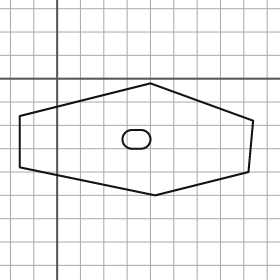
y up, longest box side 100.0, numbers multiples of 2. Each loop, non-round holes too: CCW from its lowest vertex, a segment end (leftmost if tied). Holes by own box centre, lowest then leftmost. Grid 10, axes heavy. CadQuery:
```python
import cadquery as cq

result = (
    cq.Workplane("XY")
    .moveTo(42.0, -50.0)
    .lineTo(82.0, -40.0)
    .lineTo(84.0, -18.0)
    .lineTo(40.0, -2.0)
    .lineTo(-16.0, -16.0)
    .lineTo(-16.0, -38.0)
    .close()
    .moveTo(32.0, -30.0)
    .lineTo(36.0, -30.0)
    .threePointArc((40.0, -26.0), (36.0, -22.0))
    .lineTo(32.0, -22.0)
    .threePointArc((28.0, -26.0), (32.0, -30.0))
    .close()
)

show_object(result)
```